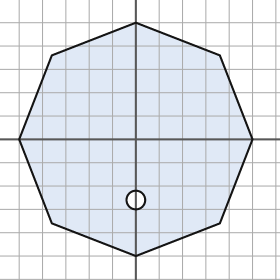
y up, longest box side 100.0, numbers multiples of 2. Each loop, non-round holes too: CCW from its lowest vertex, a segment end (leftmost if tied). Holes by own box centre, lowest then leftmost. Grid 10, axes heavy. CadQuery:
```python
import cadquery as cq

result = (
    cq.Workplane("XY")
    .moveTo(0.0, -50.0)
    .lineTo(36.0, -36.0)
    .lineTo(50.0, 0.0)
    .lineTo(36.0, 36.0)
    .lineTo(0.0, 50.0)
    .lineTo(-36.0, 36.0)
    .lineTo(-50.0, 0.0)
    .lineTo(-36.0, -36.0)
    .close()
    .moveTo(0.0, -26.0)
    .circle(4.0)
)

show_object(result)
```